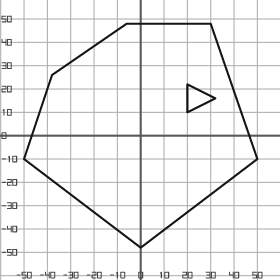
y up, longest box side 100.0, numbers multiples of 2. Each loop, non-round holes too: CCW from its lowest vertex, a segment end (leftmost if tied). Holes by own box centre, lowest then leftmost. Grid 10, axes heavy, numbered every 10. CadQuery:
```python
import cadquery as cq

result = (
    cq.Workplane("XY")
    .moveTo(0.0, -48.0)
    .lineTo(50.0, -10.0)
    .lineTo(30.0, 48.0)
    .lineTo(-6.0, 48.0)
    .lineTo(-38.0, 26.0)
    .lineTo(-50.0, -10.0)
    .close()
    .moveTo(20.0, 10.0)
    .lineTo(32.0, 16.0)
    .lineTo(20.0, 22.0)
    .close()
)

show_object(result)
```